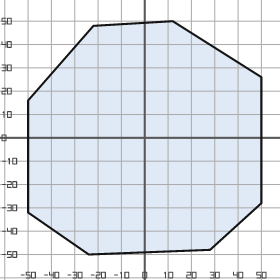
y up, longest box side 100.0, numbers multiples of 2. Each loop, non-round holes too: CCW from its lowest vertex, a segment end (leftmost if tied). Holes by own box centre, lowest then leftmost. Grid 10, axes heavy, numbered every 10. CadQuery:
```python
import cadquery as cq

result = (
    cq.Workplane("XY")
    .moveTo(-24.0, -50.0)
    .lineTo(28.0, -48.0)
    .lineTo(50.0, -28.0)
    .lineTo(50.0, 26.0)
    .lineTo(12.0, 50.0)
    .lineTo(-22.0, 48.0)
    .lineTo(-50.0, 16.0)
    .lineTo(-50.0, -32.0)
    .close()
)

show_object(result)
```